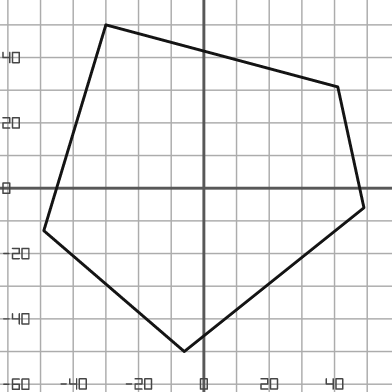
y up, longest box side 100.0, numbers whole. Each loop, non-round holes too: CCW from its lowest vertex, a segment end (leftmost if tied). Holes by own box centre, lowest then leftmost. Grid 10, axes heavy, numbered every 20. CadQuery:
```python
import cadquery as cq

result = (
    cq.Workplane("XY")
    .moveTo(-6.0, -50.0)
    .lineTo(49.0, -6.0)
    .lineTo(41.0, 31.0)
    .lineTo(-30.0, 50.0)
    .lineTo(-49.0, -13.0)
    .close()
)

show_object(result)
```